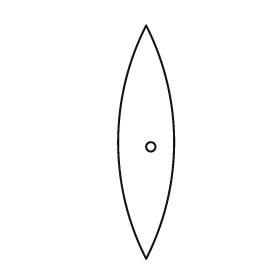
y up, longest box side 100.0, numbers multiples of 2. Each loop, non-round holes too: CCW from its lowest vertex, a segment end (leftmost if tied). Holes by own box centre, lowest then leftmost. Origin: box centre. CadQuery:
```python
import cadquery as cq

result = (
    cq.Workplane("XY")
    .moveTo(0.0, -50.0)
    .threePointArc((12.0, 0.0), (0.0, 50.0))
    .threePointArc((-12.0, 0.0), (0.0, -50.0))
    .close()
    .moveTo(2.0, -2.0)
    .circle(2.0)
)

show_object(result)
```